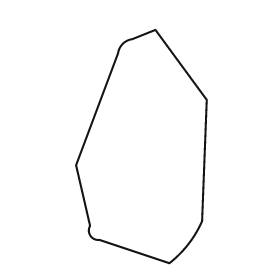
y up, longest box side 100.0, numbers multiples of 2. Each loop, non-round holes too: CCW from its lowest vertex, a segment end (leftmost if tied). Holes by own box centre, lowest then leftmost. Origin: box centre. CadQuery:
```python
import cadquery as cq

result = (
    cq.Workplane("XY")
    .moveTo(12.0, -50.0)
    .threePointArc((20.0, -42.0), (26.0, -32.0))
    .lineTo(28.0, 20.0)
    .lineTo(6.0, 50.0)
    .lineTo(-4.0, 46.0)
    .threePointArc((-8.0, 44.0), (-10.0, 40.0))
    .lineTo(-28.0, -8.0)
    .lineTo(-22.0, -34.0)
    .threePointArc((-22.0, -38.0), (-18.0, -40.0))
    .close()
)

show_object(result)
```